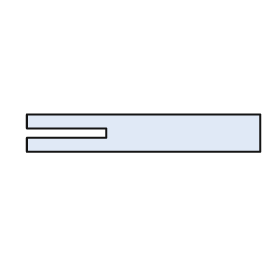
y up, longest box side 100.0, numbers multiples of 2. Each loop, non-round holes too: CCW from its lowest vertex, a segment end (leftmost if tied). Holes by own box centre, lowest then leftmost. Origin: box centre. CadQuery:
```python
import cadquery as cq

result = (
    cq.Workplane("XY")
    .moveTo(-50.0, -8.0)
    .lineTo(50.0, -8.0)
    .lineTo(50.0, 8.0)
    .lineTo(-50.0, 8.0)
    .lineTo(-50.0, 2.0)
    .lineTo(-16.0, 2.0)
    .lineTo(-16.0, -2.0)
    .lineTo(-50.0, -2.0)
    .close()
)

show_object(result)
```